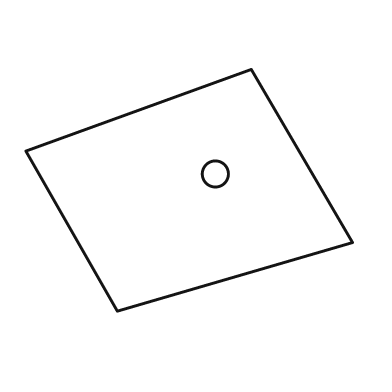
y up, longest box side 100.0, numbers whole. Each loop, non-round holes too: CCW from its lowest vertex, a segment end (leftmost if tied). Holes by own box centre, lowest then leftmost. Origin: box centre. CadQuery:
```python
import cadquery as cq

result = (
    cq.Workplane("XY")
    .moveTo(-22.0, -37.0)
    .lineTo(50.0, -16.0)
    .lineTo(19.0, 37.0)
    .lineTo(-50.0, 12.0)
    .close()
    .moveTo(8.0, 5.0)
    .circle(4.0)
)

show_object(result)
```